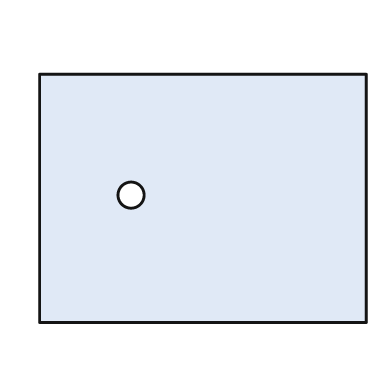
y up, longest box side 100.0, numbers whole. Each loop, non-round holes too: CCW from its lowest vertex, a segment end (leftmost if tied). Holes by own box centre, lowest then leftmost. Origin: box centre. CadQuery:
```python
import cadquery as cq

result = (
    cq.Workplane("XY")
    .moveTo(-50.0, -38.0)
    .lineTo(50.0, -38.0)
    .lineTo(50.0, 38.0)
    .lineTo(-50.0, 38.0)
    .close()
    .moveTo(-22.0, 1.0)
    .circle(4.0)
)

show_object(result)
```